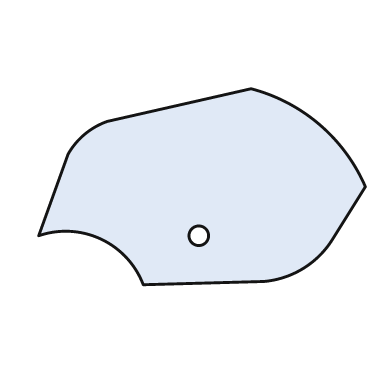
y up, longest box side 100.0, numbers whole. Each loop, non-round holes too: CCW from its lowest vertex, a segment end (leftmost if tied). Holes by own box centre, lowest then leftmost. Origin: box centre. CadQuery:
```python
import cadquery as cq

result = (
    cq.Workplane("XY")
    .moveTo(-18.0, -30.0)
    .lineTo(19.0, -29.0)
    .threePointArc((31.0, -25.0), (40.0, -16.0))
    .lineTo(50.0, 0.0)
    .threePointArc((36.0, 19.0), (15.0, 30.0))
    .lineTo(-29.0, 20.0)
    .threePointArc((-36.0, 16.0), (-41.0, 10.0))
    .lineTo(-50.0, -15.0)
    .threePointArc((-31.0, -16.0), (-18.0, -30.0))
    .close()
    .moveTo(-1.0, -15.0)
    .circle(3.0)
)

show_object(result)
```